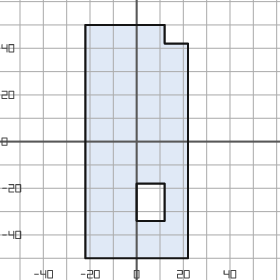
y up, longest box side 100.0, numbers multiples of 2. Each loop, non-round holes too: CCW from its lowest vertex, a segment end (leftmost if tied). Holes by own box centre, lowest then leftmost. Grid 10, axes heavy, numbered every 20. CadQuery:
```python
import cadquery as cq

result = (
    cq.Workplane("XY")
    .moveTo(-22.0, -50.0)
    .lineTo(22.0, -50.0)
    .lineTo(22.0, 42.0)
    .lineTo(12.0, 42.0)
    .lineTo(12.0, 50.0)
    .lineTo(-22.0, 50.0)
    .close()
    .moveTo(0.0, -34.0)
    .lineTo(12.0, -34.0)
    .lineTo(12.0, -18.0)
    .lineTo(0.0, -18.0)
    .close()
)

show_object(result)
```